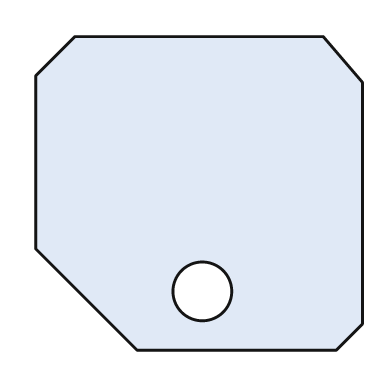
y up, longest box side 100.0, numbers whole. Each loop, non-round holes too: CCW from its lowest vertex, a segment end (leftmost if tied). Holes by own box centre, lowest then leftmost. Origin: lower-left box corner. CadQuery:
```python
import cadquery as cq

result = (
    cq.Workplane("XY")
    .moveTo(31.0, 0.0)
    .lineTo(92.0, 0.0)
    .lineTo(100.0, 8.0)
    .lineTo(100.0, 82.0)
    .lineTo(88.0, 96.0)
    .lineTo(12.0, 96.0)
    .lineTo(0.0, 84.0)
    .lineTo(0.0, 31.0)
    .close()
    .moveTo(51.0, 18.0)
    .circle(9.0)
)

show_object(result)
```